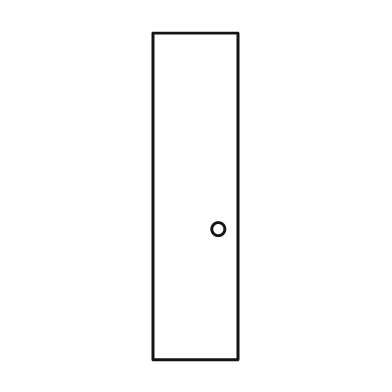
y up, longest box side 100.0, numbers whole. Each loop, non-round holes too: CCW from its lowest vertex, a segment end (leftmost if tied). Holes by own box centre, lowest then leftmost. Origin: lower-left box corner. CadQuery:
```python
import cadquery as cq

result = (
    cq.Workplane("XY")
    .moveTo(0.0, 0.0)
    .lineTo(26.0, 0.0)
    .lineTo(26.0, 100.0)
    .lineTo(0.0, 100.0)
    .close()
    .moveTo(20.0, 40.0)
    .circle(2.0)
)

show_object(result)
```